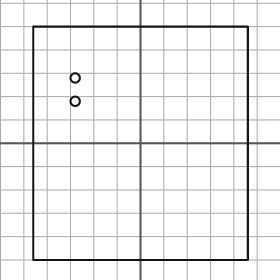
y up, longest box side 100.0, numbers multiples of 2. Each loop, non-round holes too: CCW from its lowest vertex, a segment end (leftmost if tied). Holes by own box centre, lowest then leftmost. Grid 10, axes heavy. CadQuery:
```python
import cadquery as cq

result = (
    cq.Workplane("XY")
    .moveTo(-46.0, -50.0)
    .lineTo(46.0, -50.0)
    .lineTo(46.0, 50.0)
    .lineTo(-46.0, 50.0)
    .close()
    .moveTo(-28.0, 18.0)
    .circle(2.0)
    .moveTo(-28.0, 28.0)
    .circle(2.0)
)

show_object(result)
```